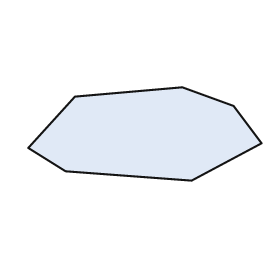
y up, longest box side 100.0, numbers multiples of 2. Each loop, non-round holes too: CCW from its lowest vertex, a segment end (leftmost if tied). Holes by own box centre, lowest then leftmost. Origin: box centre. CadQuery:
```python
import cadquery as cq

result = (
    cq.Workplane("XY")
    .moveTo(20.0, -20.0)
    .lineTo(50.0, -4.0)
    .lineTo(38.0, 12.0)
    .lineTo(16.0, 20.0)
    .lineTo(-30.0, 16.0)
    .lineTo(-50.0, -6.0)
    .lineTo(-34.0, -16.0)
    .close()
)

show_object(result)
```